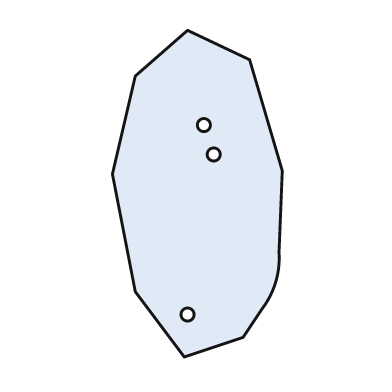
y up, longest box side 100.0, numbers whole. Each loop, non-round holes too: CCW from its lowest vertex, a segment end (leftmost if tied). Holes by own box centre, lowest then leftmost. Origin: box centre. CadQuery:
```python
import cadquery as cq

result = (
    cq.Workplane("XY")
    .moveTo(-4.0, -50.0)
    .lineTo(14.0, -44.0)
    .lineTo(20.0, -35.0)
    .threePointArc((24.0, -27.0), (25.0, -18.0))
    .lineTo(26.0, 7.0)
    .lineTo(16.0, 41.0)
    .lineTo(-3.0, 50.0)
    .lineTo(-19.0, 36.0)
    .lineTo(-26.0, 6.0)
    .lineTo(-19.0, -30.0)
    .close()
    .moveTo(-3.0, -37.0)
    .circle(2.0)
    .moveTo(5.0, 12.0)
    .circle(2.0)
    .moveTo(2.0, 21.0)
    .circle(2.0)
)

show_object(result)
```